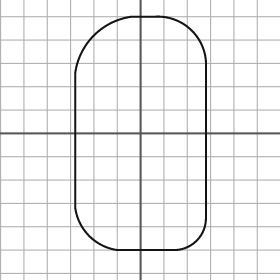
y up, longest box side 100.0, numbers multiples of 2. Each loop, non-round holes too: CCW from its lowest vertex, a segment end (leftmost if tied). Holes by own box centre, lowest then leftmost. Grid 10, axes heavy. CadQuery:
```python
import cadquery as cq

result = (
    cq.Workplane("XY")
    .moveTo(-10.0, -50.0)
    .lineTo(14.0, -50.0)
    .threePointArc((24.0, -46.0), (28.0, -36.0))
    .lineTo(28.0, 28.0)
    .threePointArc((22.0, 44.0), (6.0, 50.0))
    .lineTo(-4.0, 50.0)
    .threePointArc((-20.0, 42.0), (-28.0, 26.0))
    .lineTo(-28.0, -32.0)
    .threePointArc((-22.0, -44.0), (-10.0, -50.0))
    .close()
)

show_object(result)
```